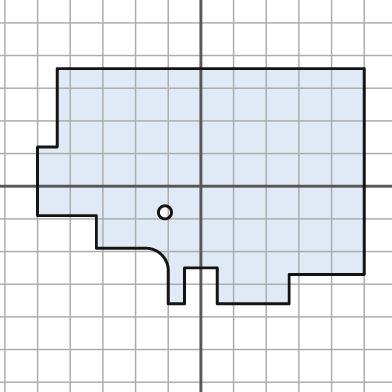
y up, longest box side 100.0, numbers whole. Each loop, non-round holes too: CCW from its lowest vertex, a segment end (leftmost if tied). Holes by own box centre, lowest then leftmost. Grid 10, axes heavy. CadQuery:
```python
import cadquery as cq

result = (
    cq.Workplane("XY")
    .moveTo(-10.0, -36.0)
    .lineTo(-5.0, -36.0)
    .lineTo(-5.0, -25.0)
    .lineTo(5.0, -25.0)
    .lineTo(5.0, -36.0)
    .lineTo(27.0, -36.0)
    .lineTo(27.0, -27.0)
    .lineTo(50.0, -27.0)
    .lineTo(50.0, 36.0)
    .lineTo(-44.0, 36.0)
    .lineTo(-44.0, 12.0)
    .lineTo(-50.0, 12.0)
    .lineTo(-50.0, -9.0)
    .lineTo(-32.0, -9.0)
    .lineTo(-32.0, -19.0)
    .lineTo(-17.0, -19.0)
    .threePointArc((-12.0, -21.0), (-10.0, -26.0))
    .close()
    .moveTo(-11.0, -8.0)
    .circle(2.0)
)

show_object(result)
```